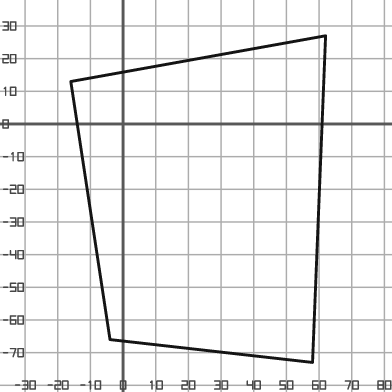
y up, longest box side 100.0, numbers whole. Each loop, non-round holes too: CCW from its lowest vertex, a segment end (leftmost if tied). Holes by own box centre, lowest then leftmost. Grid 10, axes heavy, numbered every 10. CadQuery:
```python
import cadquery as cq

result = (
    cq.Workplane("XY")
    .moveTo(58.0, -73.0)
    .lineTo(62.0, 27.0)
    .lineTo(-16.0, 13.0)
    .lineTo(-4.0, -66.0)
    .close()
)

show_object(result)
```